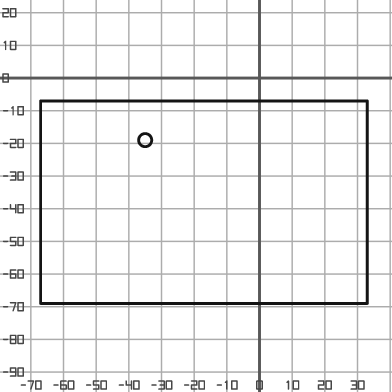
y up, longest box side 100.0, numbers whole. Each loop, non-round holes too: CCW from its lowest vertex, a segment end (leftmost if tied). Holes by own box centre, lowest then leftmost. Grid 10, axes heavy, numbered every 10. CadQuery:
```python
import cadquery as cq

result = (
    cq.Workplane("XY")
    .moveTo(-67.0, -69.0)
    .lineTo(33.0, -69.0)
    .lineTo(33.0, -7.0)
    .lineTo(-67.0, -7.0)
    .close()
    .moveTo(-35.0, -19.0)
    .circle(2.0)
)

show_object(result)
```